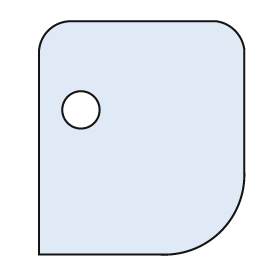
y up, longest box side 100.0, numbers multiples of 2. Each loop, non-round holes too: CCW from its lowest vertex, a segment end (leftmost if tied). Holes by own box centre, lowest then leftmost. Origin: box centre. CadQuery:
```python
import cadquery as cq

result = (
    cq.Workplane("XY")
    .moveTo(-44.0, -50.0)
    .lineTo(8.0, -50.0)
    .threePointArc((34.0, -40.0), (44.0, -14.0))
    .lineTo(44.0, 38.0)
    .threePointArc((40.0, 46.0), (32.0, 50.0))
    .lineTo(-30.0, 50.0)
    .threePointArc((-40.0, 46.0), (-44.0, 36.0))
    .close()
    .moveTo(-26.0, 12.0)
    .circle(8.0)
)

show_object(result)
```